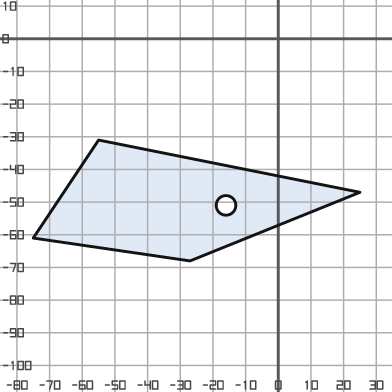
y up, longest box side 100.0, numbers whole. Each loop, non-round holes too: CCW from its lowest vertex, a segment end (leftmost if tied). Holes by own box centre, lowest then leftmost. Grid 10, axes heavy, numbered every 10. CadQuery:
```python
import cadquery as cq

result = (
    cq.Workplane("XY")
    .moveTo(-27.0, -68.0)
    .lineTo(25.0, -47.0)
    .lineTo(-55.0, -31.0)
    .lineTo(-75.0, -61.0)
    .close()
    .moveTo(-16.0, -51.0)
    .circle(3.0)
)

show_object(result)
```